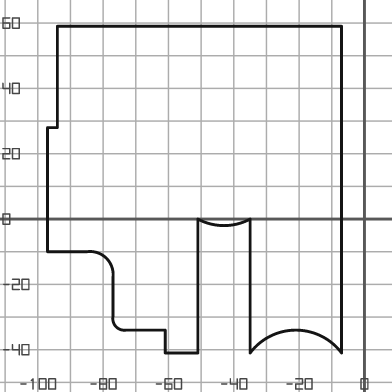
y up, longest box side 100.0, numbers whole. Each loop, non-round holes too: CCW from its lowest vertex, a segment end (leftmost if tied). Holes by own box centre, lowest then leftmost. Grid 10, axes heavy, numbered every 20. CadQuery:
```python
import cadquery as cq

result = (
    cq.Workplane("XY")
    .moveTo(-61.0, -41.0)
    .lineTo(-51.0, -41.0)
    .lineTo(-51.0, 0.0)
    .threePointArc((-43.0, -2.0), (-35.0, 0.0))
    .lineTo(-35.0, -41.0)
    .threePointArc((-21.0, -34.0), (-7.0, -41.0))
    .lineTo(-7.0, 59.0)
    .lineTo(-94.0, 59.0)
    .lineTo(-94.0, 28.0)
    .lineTo(-97.0, 28.0)
    .lineTo(-97.0, -10.0)
    .lineTo(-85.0, -10.0)
    .threePointArc((-79.0, -12.0), (-77.0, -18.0))
    .lineTo(-77.0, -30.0)
    .threePointArc((-76.0, -33.0), (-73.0, -34.0))
    .lineTo(-61.0, -34.0)
    .close()
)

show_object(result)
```